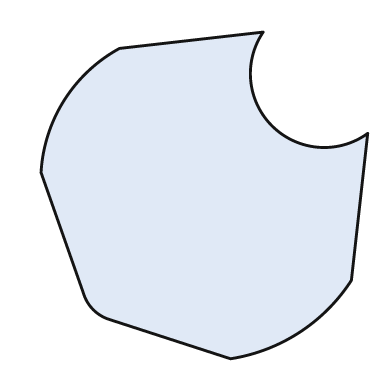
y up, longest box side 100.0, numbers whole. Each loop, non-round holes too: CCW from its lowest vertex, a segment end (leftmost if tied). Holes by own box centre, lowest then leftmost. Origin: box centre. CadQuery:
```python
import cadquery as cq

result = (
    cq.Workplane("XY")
    .moveTo(8.0, -50.0)
    .threePointArc((29.0, -42.0), (45.0, -26.0))
    .lineTo(50.0, 19.0)
    .threePointArc((21.0, 21.0), (18.0, 50.0))
    .lineTo(-26.0, 45.0)
    .threePointArc((-43.0, 29.0), (-50.0, 7.0))
    .lineTo(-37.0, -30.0)
    .threePointArc((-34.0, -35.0), (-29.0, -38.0))
    .close()
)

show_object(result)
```